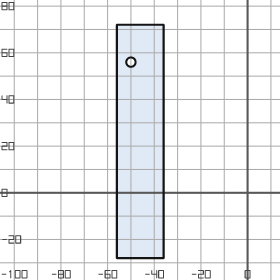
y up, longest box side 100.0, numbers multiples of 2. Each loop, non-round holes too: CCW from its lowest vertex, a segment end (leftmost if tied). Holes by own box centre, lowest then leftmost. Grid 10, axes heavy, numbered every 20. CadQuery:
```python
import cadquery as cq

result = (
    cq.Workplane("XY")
    .moveTo(-56.0, -28.0)
    .lineTo(-36.0, -28.0)
    .lineTo(-36.0, 72.0)
    .lineTo(-56.0, 72.0)
    .close()
    .moveTo(-50.0, 56.0)
    .circle(2.0)
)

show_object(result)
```